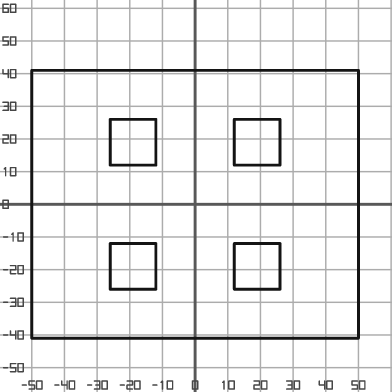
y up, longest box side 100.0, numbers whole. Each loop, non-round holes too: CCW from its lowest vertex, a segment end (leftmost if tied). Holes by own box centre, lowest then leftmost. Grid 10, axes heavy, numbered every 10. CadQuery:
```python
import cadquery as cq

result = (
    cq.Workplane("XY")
    .moveTo(-50.0, -41.0)
    .lineTo(50.0, -41.0)
    .lineTo(50.0, 41.0)
    .lineTo(-50.0, 41.0)
    .close()
    .moveTo(-26.0, -26.0)
    .lineTo(-12.0, -26.0)
    .lineTo(-12.0, -12.0)
    .lineTo(-26.0, -12.0)
    .close()
    .moveTo(12.0, -26.0)
    .lineTo(26.0, -26.0)
    .lineTo(26.0, -12.0)
    .lineTo(12.0, -12.0)
    .close()
    .moveTo(-26.0, 12.0)
    .lineTo(-12.0, 12.0)
    .lineTo(-12.0, 26.0)
    .lineTo(-26.0, 26.0)
    .close()
    .moveTo(12.0, 12.0)
    .lineTo(26.0, 12.0)
    .lineTo(26.0, 26.0)
    .lineTo(12.0, 26.0)
    .close()
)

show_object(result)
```